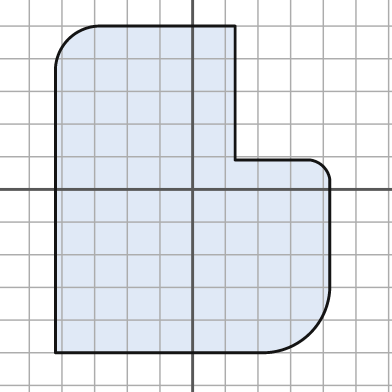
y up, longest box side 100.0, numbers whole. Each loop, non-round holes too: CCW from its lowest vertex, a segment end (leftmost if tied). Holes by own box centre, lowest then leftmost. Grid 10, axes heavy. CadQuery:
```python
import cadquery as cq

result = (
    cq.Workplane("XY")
    .moveTo(-42.0, -50.0)
    .lineTo(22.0, -50.0)
    .threePointArc((36.0, -44.0), (42.0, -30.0))
    .lineTo(42.0, 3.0)
    .threePointArc((40.0, 7.0), (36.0, 9.0))
    .lineTo(13.0, 9.0)
    .lineTo(13.0, 50.0)
    .lineTo(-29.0, 50.0)
    .threePointArc((-38.0, 46.0), (-42.0, 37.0))
    .close()
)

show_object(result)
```